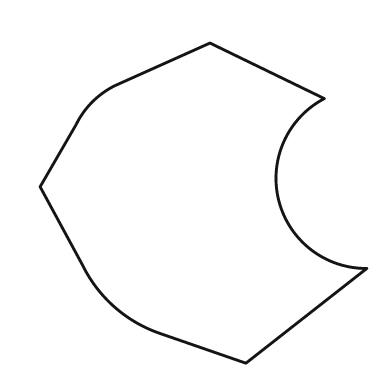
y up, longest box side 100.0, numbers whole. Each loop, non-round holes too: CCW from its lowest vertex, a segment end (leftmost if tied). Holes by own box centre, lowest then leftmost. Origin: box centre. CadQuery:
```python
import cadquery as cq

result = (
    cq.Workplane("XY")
    .moveTo(13.0, -49.0)
    .lineTo(50.0, -20.0)
    .threePointArc((23.0, 1.0), (37.0, 32.0))
    .lineTo(2.0, 49.0)
    .lineTo(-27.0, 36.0)
    .threePointArc((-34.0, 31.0), (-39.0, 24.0))
    .lineTo(-50.0, 5.0)
    .lineTo(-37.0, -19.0)
    .threePointArc((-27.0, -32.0), (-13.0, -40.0))
    .close()
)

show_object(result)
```